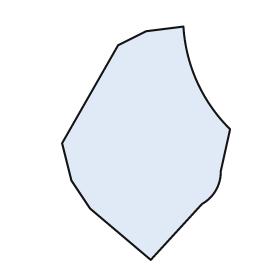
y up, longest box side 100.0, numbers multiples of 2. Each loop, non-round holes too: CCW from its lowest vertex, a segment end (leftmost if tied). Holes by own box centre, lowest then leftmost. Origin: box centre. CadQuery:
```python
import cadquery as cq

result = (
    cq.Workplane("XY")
    .moveTo(2.0, -50.0)
    .lineTo(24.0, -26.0)
    .threePointArc((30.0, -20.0), (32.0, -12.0))
    .lineTo(36.0, 6.0)
    .threePointArc((22.0, 26.0), (16.0, 50.0))
    .lineTo(0.0, 48.0)
    .lineTo(-12.0, 42.0)
    .lineTo(-36.0, 0.0)
    .lineTo(-32.0, -16.0)
    .lineTo(-24.0, -28.0)
    .close()
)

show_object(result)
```